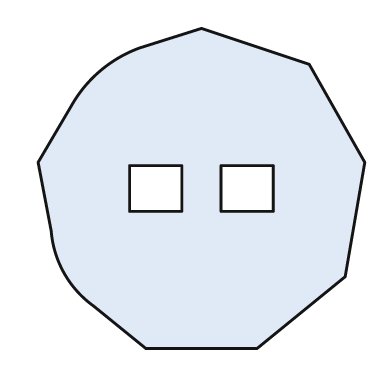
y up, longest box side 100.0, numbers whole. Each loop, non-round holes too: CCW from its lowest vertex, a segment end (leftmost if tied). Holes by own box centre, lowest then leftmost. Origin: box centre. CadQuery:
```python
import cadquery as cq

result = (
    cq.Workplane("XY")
    .moveTo(-17.0, -49.0)
    .lineTo(17.0, -49.0)
    .lineTo(44.0, -27.0)
    .lineTo(50.0, 8.0)
    .lineTo(33.0, 38.0)
    .lineTo(0.0, 49.0)
    .lineTo(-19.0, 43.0)
    .threePointArc((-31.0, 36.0), (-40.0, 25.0))
    .lineTo(-50.0, 8.0)
    .lineTo(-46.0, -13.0)
    .threePointArc((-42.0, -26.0), (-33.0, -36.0))
    .close()
    .moveTo(-22.0, -7.0)
    .lineTo(-6.0, -7.0)
    .lineTo(-6.0, 7.0)
    .lineTo(-22.0, 7.0)
    .close()
    .moveTo(6.0, -7.0)
    .lineTo(22.0, -7.0)
    .lineTo(22.0, 7.0)
    .lineTo(6.0, 7.0)
    .close()
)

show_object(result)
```